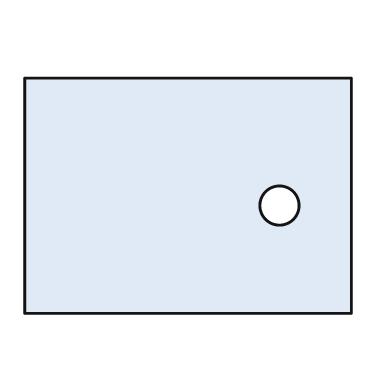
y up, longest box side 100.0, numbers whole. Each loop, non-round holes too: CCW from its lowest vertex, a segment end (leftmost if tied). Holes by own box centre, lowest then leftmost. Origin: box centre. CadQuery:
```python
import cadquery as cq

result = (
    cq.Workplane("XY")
    .moveTo(-50.0, -36.0)
    .lineTo(50.0, -36.0)
    .lineTo(50.0, 36.0)
    .lineTo(-50.0, 36.0)
    .close()
    .moveTo(28.0, -3.0)
    .circle(6.0)
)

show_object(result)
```